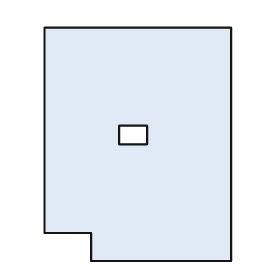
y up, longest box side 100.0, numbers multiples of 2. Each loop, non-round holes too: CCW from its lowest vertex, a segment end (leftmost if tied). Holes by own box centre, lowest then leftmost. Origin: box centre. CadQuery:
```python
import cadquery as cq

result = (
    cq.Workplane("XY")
    .moveTo(-20.0, -50.0)
    .lineTo(40.0, -50.0)
    .lineTo(40.0, 50.0)
    .lineTo(-40.0, 50.0)
    .lineTo(-40.0, -38.0)
    .lineTo(-20.0, -38.0)
    .close()
    .moveTo(-8.0, 0.0)
    .lineTo(4.0, 0.0)
    .lineTo(4.0, 8.0)
    .lineTo(-8.0, 8.0)
    .close()
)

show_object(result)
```